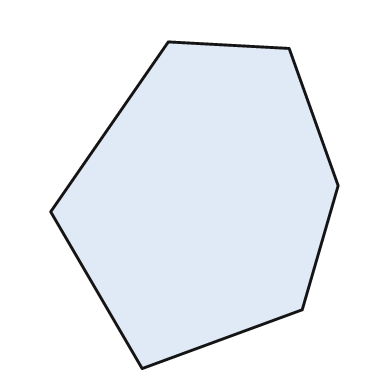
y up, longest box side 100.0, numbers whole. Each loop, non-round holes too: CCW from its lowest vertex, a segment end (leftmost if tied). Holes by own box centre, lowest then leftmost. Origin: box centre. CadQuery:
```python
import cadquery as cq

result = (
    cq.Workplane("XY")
    .moveTo(-16.0, -50.0)
    .lineTo(33.0, -32.0)
    .lineTo(44.0, 6.0)
    .lineTo(29.0, 48.0)
    .lineTo(-8.0, 50.0)
    .lineTo(-44.0, -2.0)
    .close()
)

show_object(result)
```